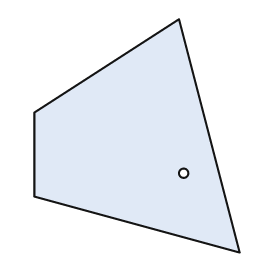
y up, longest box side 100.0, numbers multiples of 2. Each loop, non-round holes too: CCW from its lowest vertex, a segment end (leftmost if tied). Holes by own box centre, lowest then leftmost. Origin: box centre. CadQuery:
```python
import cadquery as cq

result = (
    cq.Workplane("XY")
    .moveTo(44.0, -50.0)
    .lineTo(18.0, 50.0)
    .lineTo(-44.0, 10.0)
    .lineTo(-44.0, -26.0)
    .close()
    .moveTo(20.0, -16.0)
    .circle(2.0)
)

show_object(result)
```